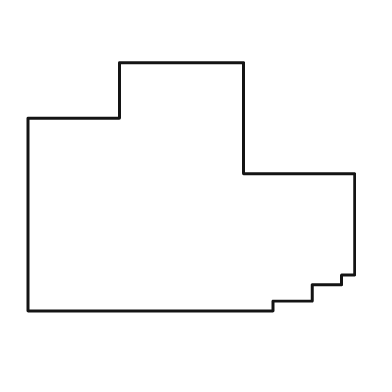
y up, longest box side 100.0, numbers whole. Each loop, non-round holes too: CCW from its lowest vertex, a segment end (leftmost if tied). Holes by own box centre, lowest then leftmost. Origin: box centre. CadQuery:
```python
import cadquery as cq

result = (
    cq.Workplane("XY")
    .moveTo(-50.0, -38.0)
    .lineTo(25.0, -38.0)
    .lineTo(25.0, -35.0)
    .lineTo(37.0, -35.0)
    .lineTo(37.0, -30.0)
    .lineTo(46.0, -30.0)
    .lineTo(46.0, -27.0)
    .lineTo(50.0, -27.0)
    .lineTo(50.0, 4.0)
    .lineTo(16.0, 4.0)
    .lineTo(16.0, 38.0)
    .lineTo(-22.0, 38.0)
    .lineTo(-22.0, 21.0)
    .lineTo(-50.0, 21.0)
    .close()
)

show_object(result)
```